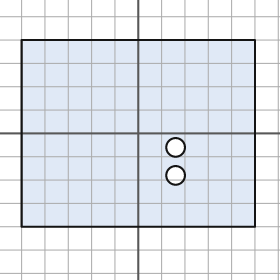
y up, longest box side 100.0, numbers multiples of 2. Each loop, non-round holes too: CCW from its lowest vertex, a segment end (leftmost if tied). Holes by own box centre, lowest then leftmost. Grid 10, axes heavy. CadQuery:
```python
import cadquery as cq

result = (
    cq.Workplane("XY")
    .moveTo(-50.0, -40.0)
    .lineTo(50.0, -40.0)
    .lineTo(50.0, 40.0)
    .lineTo(-50.0, 40.0)
    .close()
    .moveTo(16.0, -18.0)
    .circle(4.0)
    .moveTo(16.0, -6.0)
    .circle(4.0)
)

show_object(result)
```